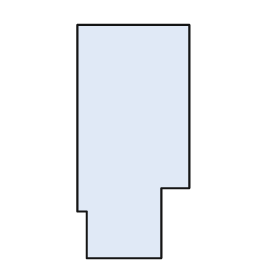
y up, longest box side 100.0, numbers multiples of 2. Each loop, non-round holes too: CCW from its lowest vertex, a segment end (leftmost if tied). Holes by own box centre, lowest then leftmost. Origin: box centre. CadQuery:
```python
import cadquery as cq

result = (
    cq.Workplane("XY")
    .moveTo(-20.0, -50.0)
    .lineTo(12.0, -50.0)
    .lineTo(12.0, -20.0)
    .lineTo(24.0, -20.0)
    .lineTo(24.0, 50.0)
    .lineTo(-24.0, 50.0)
    .lineTo(-24.0, -30.0)
    .lineTo(-20.0, -30.0)
    .close()
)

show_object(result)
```